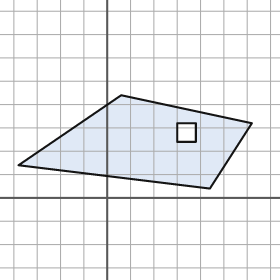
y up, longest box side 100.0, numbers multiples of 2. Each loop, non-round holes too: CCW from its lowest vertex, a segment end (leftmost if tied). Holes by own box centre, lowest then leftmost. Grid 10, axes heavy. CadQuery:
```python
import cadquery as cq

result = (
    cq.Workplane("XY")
    .moveTo(44.0, 4.0)
    .lineTo(62.0, 32.0)
    .lineTo(6.0, 44.0)
    .lineTo(-38.0, 14.0)
    .close()
    .moveTo(30.0, 24.0)
    .lineTo(38.0, 24.0)
    .lineTo(38.0, 32.0)
    .lineTo(30.0, 32.0)
    .close()
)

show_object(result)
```